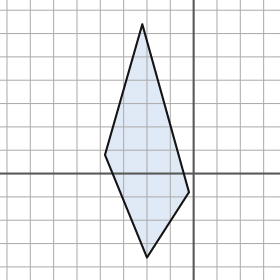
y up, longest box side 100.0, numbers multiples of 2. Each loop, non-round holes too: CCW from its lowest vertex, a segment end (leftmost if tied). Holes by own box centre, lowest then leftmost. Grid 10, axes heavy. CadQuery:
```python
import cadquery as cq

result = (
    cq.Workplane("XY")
    .moveTo(-20.0, -36.0)
    .lineTo(-2.0, -8.0)
    .lineTo(-22.0, 64.0)
    .lineTo(-38.0, 8.0)
    .close()
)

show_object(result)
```